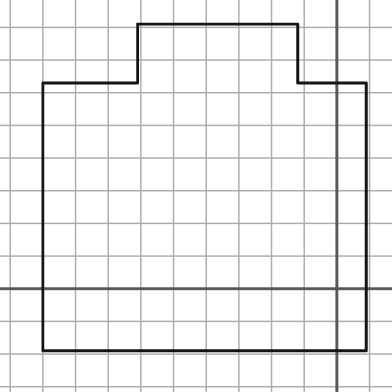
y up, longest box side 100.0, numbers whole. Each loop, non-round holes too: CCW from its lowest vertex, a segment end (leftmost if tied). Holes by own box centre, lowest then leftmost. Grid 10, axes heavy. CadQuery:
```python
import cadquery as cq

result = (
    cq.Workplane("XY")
    .moveTo(-90.0, -19.0)
    .lineTo(9.0, -19.0)
    .lineTo(9.0, 63.0)
    .lineTo(-12.0, 63.0)
    .lineTo(-12.0, 81.0)
    .lineTo(-61.0, 81.0)
    .lineTo(-61.0, 63.0)
    .lineTo(-90.0, 63.0)
    .close()
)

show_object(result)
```